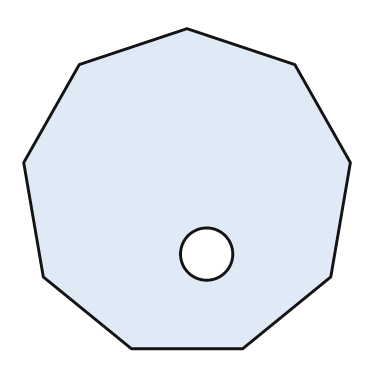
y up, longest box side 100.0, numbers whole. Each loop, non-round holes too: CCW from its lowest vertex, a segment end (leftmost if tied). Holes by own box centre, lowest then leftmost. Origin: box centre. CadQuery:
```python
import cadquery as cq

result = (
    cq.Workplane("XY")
    .moveTo(-17.0, -49.0)
    .lineTo(17.0, -49.0)
    .lineTo(44.0, -27.0)
    .lineTo(50.0, 8.0)
    .lineTo(33.0, 38.0)
    .lineTo(0.0, 49.0)
    .lineTo(-33.0, 38.0)
    .lineTo(-50.0, 8.0)
    .lineTo(-44.0, -27.0)
    .close()
    .moveTo(6.0, -20.0)
    .circle(8.0)
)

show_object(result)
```